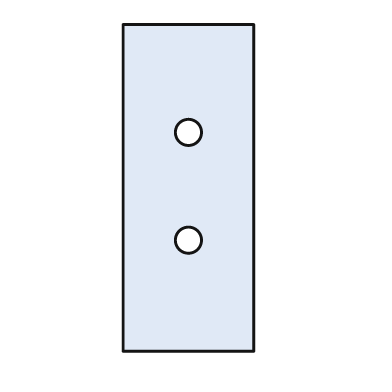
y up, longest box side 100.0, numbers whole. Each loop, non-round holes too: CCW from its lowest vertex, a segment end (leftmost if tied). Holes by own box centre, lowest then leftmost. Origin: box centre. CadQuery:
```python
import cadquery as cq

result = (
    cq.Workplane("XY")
    .moveTo(-20.0, -50.0)
    .lineTo(20.0, -50.0)
    .lineTo(20.0, 50.0)
    .lineTo(-20.0, 50.0)
    .close()
    .moveTo(0.0, -16.0)
    .circle(4.0)
    .moveTo(0.0, 17.0)
    .circle(4.0)
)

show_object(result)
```